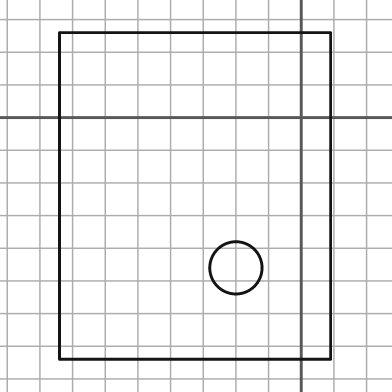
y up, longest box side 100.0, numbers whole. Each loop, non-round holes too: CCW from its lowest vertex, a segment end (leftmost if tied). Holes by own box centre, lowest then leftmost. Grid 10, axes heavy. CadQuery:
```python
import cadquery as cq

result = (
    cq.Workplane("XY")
    .moveTo(-74.0, -74.0)
    .lineTo(9.0, -74.0)
    .lineTo(9.0, 26.0)
    .lineTo(-74.0, 26.0)
    .close()
    .moveTo(-20.0, -46.0)
    .circle(8.0)
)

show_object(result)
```